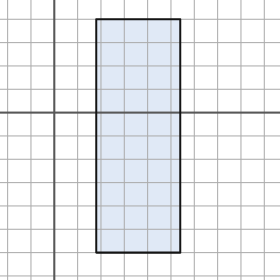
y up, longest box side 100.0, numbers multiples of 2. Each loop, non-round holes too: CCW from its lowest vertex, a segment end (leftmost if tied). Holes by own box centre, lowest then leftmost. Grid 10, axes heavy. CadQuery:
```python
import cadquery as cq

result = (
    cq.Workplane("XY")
    .moveTo(18.0, -60.0)
    .lineTo(54.0, -60.0)
    .lineTo(54.0, 40.0)
    .lineTo(18.0, 40.0)
    .close()
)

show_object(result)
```